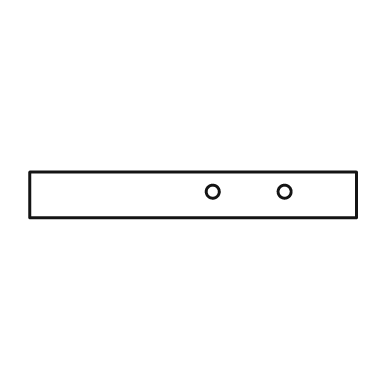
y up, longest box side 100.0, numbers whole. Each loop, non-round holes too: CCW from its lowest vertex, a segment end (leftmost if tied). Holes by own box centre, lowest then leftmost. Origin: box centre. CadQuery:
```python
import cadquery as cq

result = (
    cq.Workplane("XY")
    .moveTo(-50.0, -7.0)
    .lineTo(50.0, -7.0)
    .lineTo(50.0, 7.0)
    .lineTo(-50.0, 7.0)
    .close()
    .moveTo(6.0, 1.0)
    .circle(2.0)
    .moveTo(28.0, 1.0)
    .circle(2.0)
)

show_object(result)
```